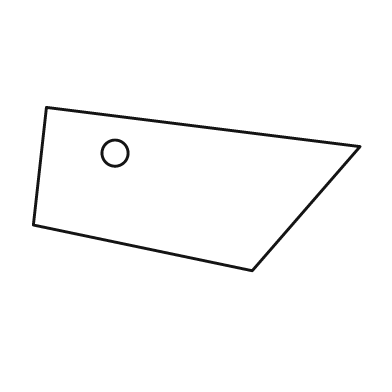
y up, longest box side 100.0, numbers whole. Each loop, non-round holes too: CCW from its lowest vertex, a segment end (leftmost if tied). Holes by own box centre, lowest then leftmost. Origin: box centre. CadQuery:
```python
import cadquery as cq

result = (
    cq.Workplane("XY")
    .moveTo(17.0, -25.0)
    .lineTo(50.0, 13.0)
    .lineTo(-46.0, 25.0)
    .lineTo(-50.0, -11.0)
    .close()
    .moveTo(-25.0, 11.0)
    .circle(4.0)
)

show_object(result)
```